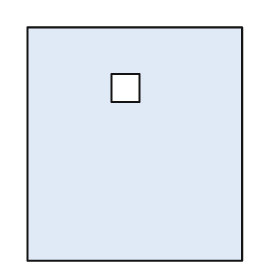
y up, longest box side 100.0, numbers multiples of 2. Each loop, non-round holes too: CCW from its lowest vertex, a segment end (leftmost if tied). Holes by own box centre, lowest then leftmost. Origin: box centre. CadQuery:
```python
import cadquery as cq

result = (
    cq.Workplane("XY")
    .moveTo(-46.0, -50.0)
    .lineTo(46.0, -50.0)
    .lineTo(46.0, 50.0)
    .lineTo(-46.0, 50.0)
    .close()
    .moveTo(-10.0, 18.0)
    .lineTo(2.0, 18.0)
    .lineTo(2.0, 30.0)
    .lineTo(-10.0, 30.0)
    .close()
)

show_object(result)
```